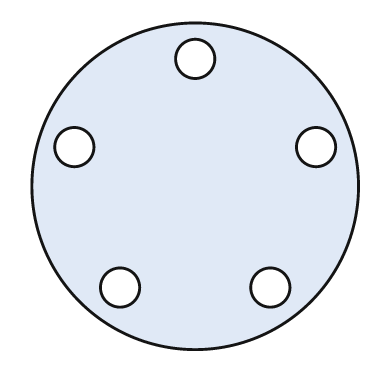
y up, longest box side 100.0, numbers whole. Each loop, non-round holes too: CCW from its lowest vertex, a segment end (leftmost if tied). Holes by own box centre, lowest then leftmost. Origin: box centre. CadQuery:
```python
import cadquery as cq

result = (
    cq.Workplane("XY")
    .moveTo(0.0, 0.0)
    .circle(50.0)
    .moveTo(-23.0, -31.0)
    .circle(6.0)
    .moveTo(23.0, -31.0)
    .circle(6.0)
    .moveTo(-37.0, 12.0)
    .circle(6.0)
    .moveTo(37.0, 12.0)
    .circle(6.0)
    .moveTo(0.0, 39.0)
    .circle(6.0)
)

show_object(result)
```